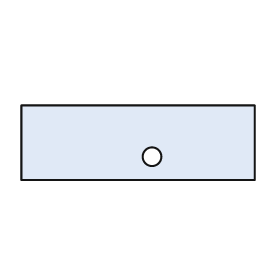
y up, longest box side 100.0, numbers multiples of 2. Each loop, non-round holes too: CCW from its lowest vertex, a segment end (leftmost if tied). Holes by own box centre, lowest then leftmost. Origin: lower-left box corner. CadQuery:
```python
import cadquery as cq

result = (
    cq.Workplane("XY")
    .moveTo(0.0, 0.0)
    .lineTo(100.0, 0.0)
    .lineTo(100.0, 32.0)
    .lineTo(0.0, 32.0)
    .close()
    .moveTo(56.0, 10.0)
    .circle(4.0)
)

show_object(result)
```